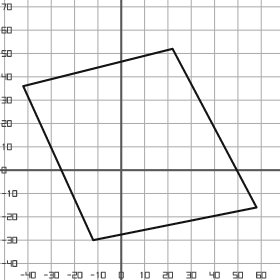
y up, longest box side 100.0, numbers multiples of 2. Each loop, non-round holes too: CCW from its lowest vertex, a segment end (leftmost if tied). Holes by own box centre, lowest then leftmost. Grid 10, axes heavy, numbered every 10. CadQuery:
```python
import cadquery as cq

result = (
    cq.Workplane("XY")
    .moveTo(-12.0, -30.0)
    .lineTo(58.0, -16.0)
    .lineTo(22.0, 52.0)
    .lineTo(-42.0, 36.0)
    .close()
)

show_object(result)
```